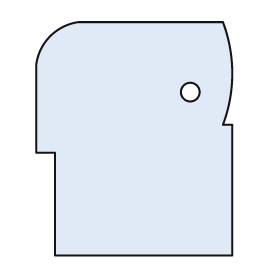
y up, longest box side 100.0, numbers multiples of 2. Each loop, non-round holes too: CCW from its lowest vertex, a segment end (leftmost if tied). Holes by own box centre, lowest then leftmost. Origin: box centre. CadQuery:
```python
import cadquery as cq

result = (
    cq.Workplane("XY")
    .moveTo(-34.0, -50.0)
    .lineTo(42.0, -50.0)
    .lineTo(42.0, 6.0)
    .lineTo(38.0, 6.0)
    .threePointArc((42.0, 28.0), (38.0, 50.0))
    .lineTo(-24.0, 50.0)
    .threePointArc((-36.0, 44.0), (-42.0, 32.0))
    .lineTo(-42.0, -6.0)
    .lineTo(-34.0, -6.0)
    .close()
    .moveTo(24.0, 20.0)
    .circle(4.0)
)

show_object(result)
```